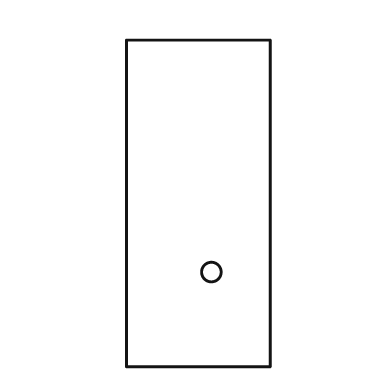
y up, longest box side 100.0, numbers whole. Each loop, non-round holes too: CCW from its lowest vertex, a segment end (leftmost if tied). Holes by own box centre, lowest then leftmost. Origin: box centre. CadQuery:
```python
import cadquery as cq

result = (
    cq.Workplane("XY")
    .moveTo(-22.0, -50.0)
    .lineTo(22.0, -50.0)
    .lineTo(22.0, 50.0)
    .lineTo(-22.0, 50.0)
    .close()
    .moveTo(4.0, -21.0)
    .circle(3.0)
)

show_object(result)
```